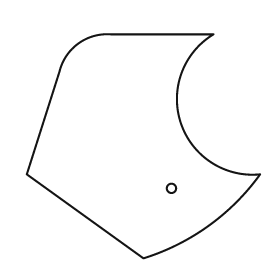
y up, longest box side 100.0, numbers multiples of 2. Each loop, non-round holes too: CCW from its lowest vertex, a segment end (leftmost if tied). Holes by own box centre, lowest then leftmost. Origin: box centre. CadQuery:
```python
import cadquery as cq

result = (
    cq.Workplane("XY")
    .moveTo(0.0, -48.0)
    .threePointArc((28.0, -34.0), (50.0, -12.0))
    .threePointArc((16.0, 10.0), (30.0, 48.0))
    .lineTo(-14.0, 48.0)
    .threePointArc((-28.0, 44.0), (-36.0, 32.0))
    .lineTo(-50.0, -12.0)
    .close()
    .moveTo(12.0, -18.0)
    .circle(2.0)
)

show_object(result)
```